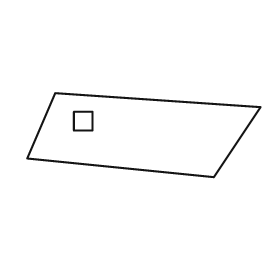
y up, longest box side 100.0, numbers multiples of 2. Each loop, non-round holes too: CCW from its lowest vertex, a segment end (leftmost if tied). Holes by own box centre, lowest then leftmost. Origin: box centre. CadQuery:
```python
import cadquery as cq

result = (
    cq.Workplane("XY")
    .moveTo(30.0, -18.0)
    .lineTo(50.0, 12.0)
    .lineTo(-38.0, 18.0)
    .lineTo(-50.0, -10.0)
    .close()
    .moveTo(-30.0, 2.0)
    .lineTo(-22.0, 2.0)
    .lineTo(-22.0, 10.0)
    .lineTo(-30.0, 10.0)
    .close()
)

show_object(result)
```